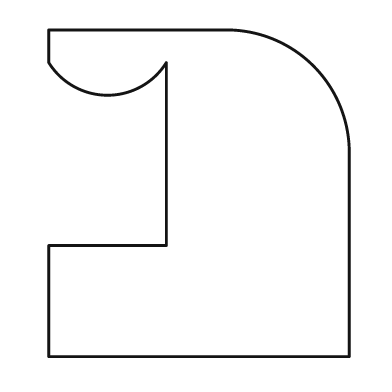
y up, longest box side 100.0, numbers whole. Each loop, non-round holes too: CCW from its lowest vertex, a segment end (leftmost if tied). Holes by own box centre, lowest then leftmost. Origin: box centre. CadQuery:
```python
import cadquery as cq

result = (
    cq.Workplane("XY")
    .moveTo(-46.0, -50.0)
    .lineTo(46.0, -50.0)
    .lineTo(46.0, 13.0)
    .threePointArc((35.0, 39.0), (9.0, 50.0))
    .lineTo(-46.0, 50.0)
    .lineTo(-46.0, 40.0)
    .threePointArc((-28.0, 30.0), (-10.0, 40.0))
    .lineTo(-10.0, -16.0)
    .lineTo(-46.0, -16.0)
    .close()
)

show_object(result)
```